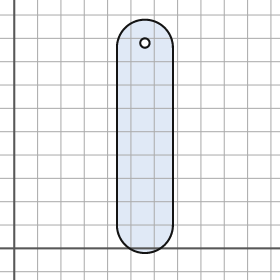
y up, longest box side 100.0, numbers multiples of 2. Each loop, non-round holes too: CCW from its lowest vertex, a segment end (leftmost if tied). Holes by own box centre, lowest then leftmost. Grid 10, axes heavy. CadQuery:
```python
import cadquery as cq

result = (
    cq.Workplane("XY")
    .moveTo(44.0, 10.0)
    .threePointArc((56.0, -2.0), (68.0, 10.0))
    .lineTo(68.0, 86.0)
    .threePointArc((56.0, 98.0), (44.0, 86.0))
    .close()
    .moveTo(56.0, 88.0)
    .circle(2.0)
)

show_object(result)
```